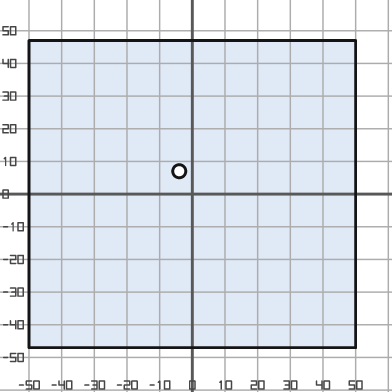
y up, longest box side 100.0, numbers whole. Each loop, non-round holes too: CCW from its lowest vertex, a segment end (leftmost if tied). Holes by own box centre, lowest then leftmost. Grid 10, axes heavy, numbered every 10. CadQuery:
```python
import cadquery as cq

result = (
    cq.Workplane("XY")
    .moveTo(-50.0, -47.0)
    .lineTo(50.0, -47.0)
    .lineTo(50.0, 47.0)
    .lineTo(-50.0, 47.0)
    .close()
    .moveTo(-4.0, 7.0)
    .circle(2.0)
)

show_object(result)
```